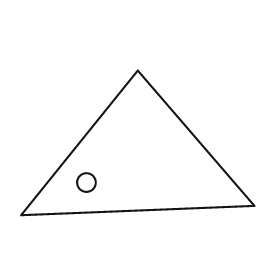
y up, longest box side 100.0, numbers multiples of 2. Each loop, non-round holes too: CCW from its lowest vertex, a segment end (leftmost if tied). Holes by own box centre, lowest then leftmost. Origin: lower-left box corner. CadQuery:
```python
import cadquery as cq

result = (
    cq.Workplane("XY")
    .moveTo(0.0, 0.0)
    .lineTo(100.0, 4.0)
    .lineTo(50.0, 62.0)
    .close()
    .moveTo(28.0, 14.0)
    .circle(4.0)
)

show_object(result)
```